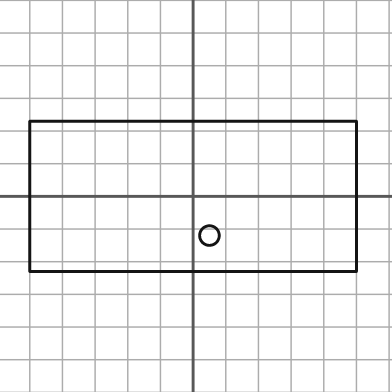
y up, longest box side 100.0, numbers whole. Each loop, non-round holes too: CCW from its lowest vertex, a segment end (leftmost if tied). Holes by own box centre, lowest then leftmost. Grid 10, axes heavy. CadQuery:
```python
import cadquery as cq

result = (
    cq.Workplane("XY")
    .moveTo(-50.0, -23.0)
    .lineTo(50.0, -23.0)
    .lineTo(50.0, 23.0)
    .lineTo(-50.0, 23.0)
    .close()
    .moveTo(5.0, -12.0)
    .circle(3.0)
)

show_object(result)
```